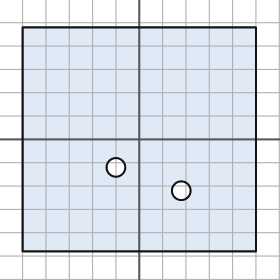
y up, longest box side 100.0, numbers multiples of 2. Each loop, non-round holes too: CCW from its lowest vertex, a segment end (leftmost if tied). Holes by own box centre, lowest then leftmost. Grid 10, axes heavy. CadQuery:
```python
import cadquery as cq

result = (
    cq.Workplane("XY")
    .moveTo(-50.0, -48.0)
    .lineTo(50.0, -48.0)
    .lineTo(50.0, 48.0)
    .lineTo(-50.0, 48.0)
    .close()
    .moveTo(18.0, -22.0)
    .circle(4.0)
    .moveTo(-10.0, -12.0)
    .circle(4.0)
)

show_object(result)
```